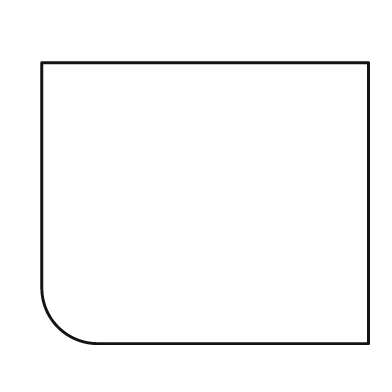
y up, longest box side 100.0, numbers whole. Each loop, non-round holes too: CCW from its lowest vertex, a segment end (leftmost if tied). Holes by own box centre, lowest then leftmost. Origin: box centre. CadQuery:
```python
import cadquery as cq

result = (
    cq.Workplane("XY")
    .moveTo(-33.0, -43.0)
    .lineTo(50.0, -43.0)
    .lineTo(50.0, 43.0)
    .lineTo(-50.0, 43.0)
    .lineTo(-50.0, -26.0)
    .threePointArc((-45.0, -38.0), (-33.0, -43.0))
    .close()
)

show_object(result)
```